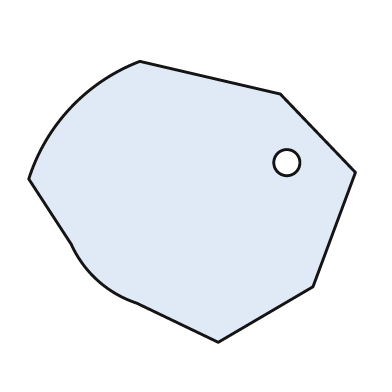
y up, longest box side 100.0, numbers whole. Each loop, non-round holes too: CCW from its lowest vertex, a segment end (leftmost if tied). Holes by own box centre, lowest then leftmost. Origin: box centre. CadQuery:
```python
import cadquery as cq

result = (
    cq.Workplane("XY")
    .moveTo(8.0, -43.0)
    .lineTo(37.0, -26.0)
    .lineTo(50.0, 9.0)
    .lineTo(27.0, 33.0)
    .lineTo(-16.0, 43.0)
    .threePointArc((-37.0, 29.0), (-50.0, 7.0))
    .lineTo(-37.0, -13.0)
    .threePointArc((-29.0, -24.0), (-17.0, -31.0))
    .close()
    .moveTo(29.0, 12.0)
    .circle(4.0)
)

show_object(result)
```